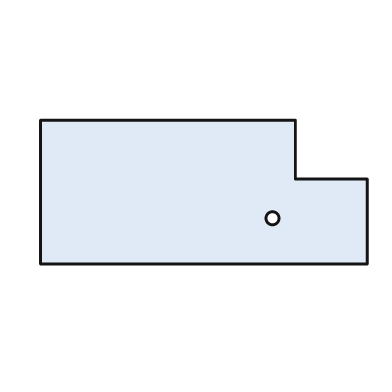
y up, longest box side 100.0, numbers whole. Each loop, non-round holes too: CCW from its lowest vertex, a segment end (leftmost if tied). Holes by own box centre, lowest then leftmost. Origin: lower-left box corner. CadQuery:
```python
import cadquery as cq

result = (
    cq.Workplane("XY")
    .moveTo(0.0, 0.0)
    .lineTo(100.0, 0.0)
    .lineTo(100.0, 26.0)
    .lineTo(78.0, 26.0)
    .lineTo(78.0, 44.0)
    .lineTo(0.0, 44.0)
    .close()
    .moveTo(71.0, 14.0)
    .circle(2.0)
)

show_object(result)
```